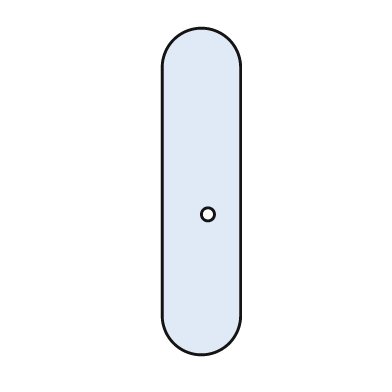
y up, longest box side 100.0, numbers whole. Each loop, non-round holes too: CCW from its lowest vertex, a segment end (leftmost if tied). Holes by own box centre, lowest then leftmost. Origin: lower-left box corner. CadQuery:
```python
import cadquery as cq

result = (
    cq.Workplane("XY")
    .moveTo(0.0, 12.0)
    .threePointArc((12.0, 0.0), (24.0, 12.0))
    .lineTo(24.0, 88.0)
    .threePointArc((12.0, 100.0), (0.0, 88.0))
    .close()
    .moveTo(14.0, 43.0)
    .circle(2.0)
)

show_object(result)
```